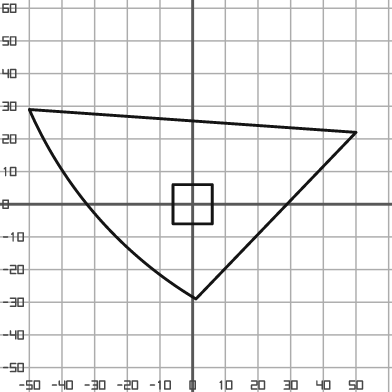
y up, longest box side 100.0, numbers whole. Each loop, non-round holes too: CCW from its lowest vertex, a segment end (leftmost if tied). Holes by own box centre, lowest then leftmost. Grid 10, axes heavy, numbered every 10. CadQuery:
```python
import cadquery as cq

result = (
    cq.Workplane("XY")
    .moveTo(1.0, -29.0)
    .lineTo(50.0, 22.0)
    .lineTo(-50.0, 29.0)
    .threePointArc((-29.0, -4.0), (1.0, -29.0))
    .close()
    .moveTo(-6.0, -6.0)
    .lineTo(6.0, -6.0)
    .lineTo(6.0, 6.0)
    .lineTo(-6.0, 6.0)
    .close()
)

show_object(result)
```